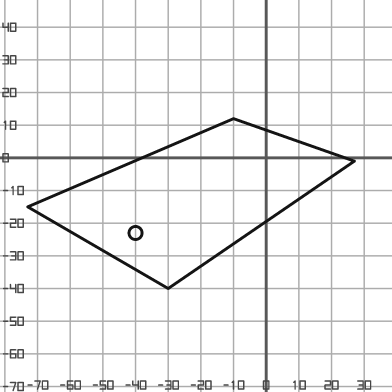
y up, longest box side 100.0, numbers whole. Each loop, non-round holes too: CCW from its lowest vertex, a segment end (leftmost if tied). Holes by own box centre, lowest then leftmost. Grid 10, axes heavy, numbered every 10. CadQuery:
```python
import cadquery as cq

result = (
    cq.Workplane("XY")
    .moveTo(-30.0, -40.0)
    .lineTo(27.0, -1.0)
    .lineTo(-10.0, 12.0)
    .lineTo(-73.0, -15.0)
    .close()
    .moveTo(-40.0, -23.0)
    .circle(2.0)
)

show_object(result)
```